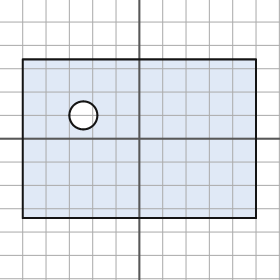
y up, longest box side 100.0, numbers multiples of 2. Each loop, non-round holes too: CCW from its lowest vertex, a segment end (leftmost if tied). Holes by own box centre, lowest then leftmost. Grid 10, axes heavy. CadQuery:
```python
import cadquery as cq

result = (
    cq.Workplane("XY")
    .moveTo(-50.0, -34.0)
    .lineTo(50.0, -34.0)
    .lineTo(50.0, 34.0)
    .lineTo(-50.0, 34.0)
    .close()
    .moveTo(-24.0, 10.0)
    .circle(6.0)
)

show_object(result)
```